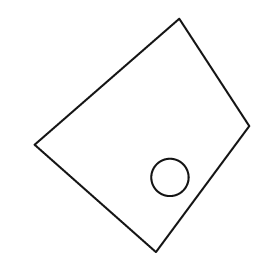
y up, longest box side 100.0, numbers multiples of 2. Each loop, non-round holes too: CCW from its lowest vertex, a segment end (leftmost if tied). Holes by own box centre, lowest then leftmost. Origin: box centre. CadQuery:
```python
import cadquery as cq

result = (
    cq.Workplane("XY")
    .moveTo(6.0, -50.0)
    .lineTo(46.0, 4.0)
    .lineTo(16.0, 50.0)
    .lineTo(-46.0, -4.0)
    .close()
    .moveTo(12.0, -18.0)
    .circle(8.0)
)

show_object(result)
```